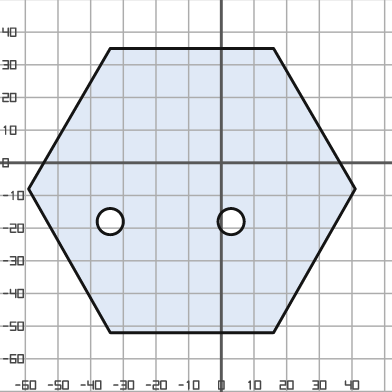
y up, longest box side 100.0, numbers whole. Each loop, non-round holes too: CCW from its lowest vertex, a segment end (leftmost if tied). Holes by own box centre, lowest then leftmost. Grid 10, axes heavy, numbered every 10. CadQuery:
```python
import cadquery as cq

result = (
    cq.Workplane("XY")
    .moveTo(-34.0, -52.0)
    .lineTo(16.0, -52.0)
    .lineTo(41.0, -8.0)
    .lineTo(16.0, 35.0)
    .lineTo(-34.0, 35.0)
    .lineTo(-59.0, -8.0)
    .close()
    .moveTo(-34.0, -18.0)
    .circle(4.0)
    .moveTo(3.0, -18.0)
    .circle(4.0)
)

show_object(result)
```